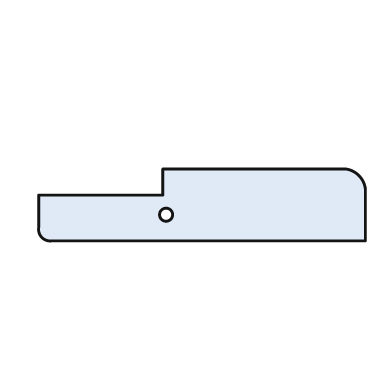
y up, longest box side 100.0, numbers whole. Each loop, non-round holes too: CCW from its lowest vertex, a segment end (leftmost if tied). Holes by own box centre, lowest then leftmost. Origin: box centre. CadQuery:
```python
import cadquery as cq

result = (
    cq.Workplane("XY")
    .moveTo(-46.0, -11.0)
    .lineTo(50.0, -11.0)
    .lineTo(50.0, 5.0)
    .threePointArc((48.0, 9.0), (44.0, 11.0))
    .lineTo(-12.0, 11.0)
    .lineTo(-12.0, 3.0)
    .lineTo(-50.0, 3.0)
    .lineTo(-50.0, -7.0)
    .threePointArc((-49.0, -10.0), (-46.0, -11.0))
    .close()
    .moveTo(-11.0, -3.0)
    .circle(2.0)
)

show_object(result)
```